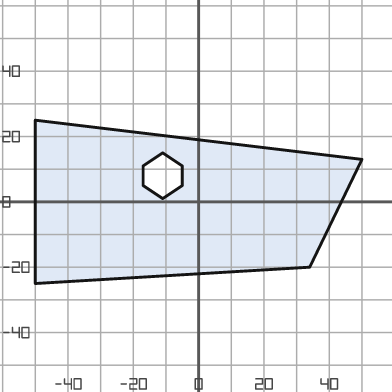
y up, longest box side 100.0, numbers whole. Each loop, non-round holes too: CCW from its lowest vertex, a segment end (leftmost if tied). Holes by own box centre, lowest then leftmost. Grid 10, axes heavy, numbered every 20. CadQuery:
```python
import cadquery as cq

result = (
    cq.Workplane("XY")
    .moveTo(-50.0, -25.0)
    .lineTo(34.0, -20.0)
    .lineTo(50.0, 13.0)
    .lineTo(-50.0, 25.0)
    .close()
    .moveTo(-11.0, 1.0)
    .lineTo(-5.0, 5.0)
    .lineTo(-5.0, 11.0)
    .lineTo(-11.0, 15.0)
    .lineTo(-17.0, 11.0)
    .lineTo(-17.0, 5.0)
    .close()
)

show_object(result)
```